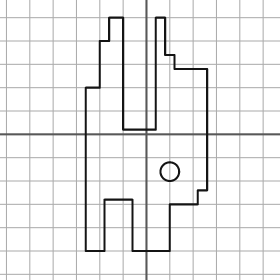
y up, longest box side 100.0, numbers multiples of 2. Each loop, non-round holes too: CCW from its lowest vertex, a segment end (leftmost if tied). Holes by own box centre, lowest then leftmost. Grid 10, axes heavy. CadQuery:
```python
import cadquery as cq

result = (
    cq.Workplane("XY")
    .moveTo(-26.0, -50.0)
    .lineTo(-18.0, -50.0)
    .lineTo(-18.0, -28.0)
    .lineTo(-6.0, -28.0)
    .lineTo(-6.0, -50.0)
    .lineTo(10.0, -50.0)
    .lineTo(10.0, -30.0)
    .lineTo(22.0, -30.0)
    .lineTo(22.0, -24.0)
    .lineTo(26.0, -24.0)
    .lineTo(26.0, 28.0)
    .lineTo(12.0, 28.0)
    .lineTo(12.0, 34.0)
    .lineTo(8.0, 34.0)
    .lineTo(8.0, 50.0)
    .lineTo(4.0, 50.0)
    .lineTo(4.0, 2.0)
    .lineTo(-10.0, 2.0)
    .lineTo(-10.0, 50.0)
    .lineTo(-16.0, 50.0)
    .lineTo(-16.0, 40.0)
    .lineTo(-20.0, 40.0)
    .lineTo(-20.0, 20.0)
    .lineTo(-26.0, 20.0)
    .close()
    .moveTo(10.0, -16.0)
    .circle(4.0)
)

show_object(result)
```